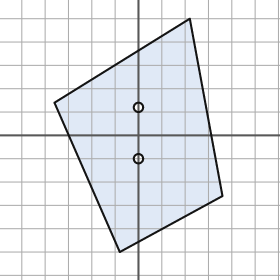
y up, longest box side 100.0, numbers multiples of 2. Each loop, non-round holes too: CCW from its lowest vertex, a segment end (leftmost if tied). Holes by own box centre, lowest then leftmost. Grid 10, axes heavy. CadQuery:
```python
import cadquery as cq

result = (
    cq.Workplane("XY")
    .moveTo(-8.0, -50.0)
    .lineTo(36.0, -26.0)
    .lineTo(22.0, 50.0)
    .lineTo(-36.0, 14.0)
    .close()
    .moveTo(0.0, -10.0)
    .circle(2.0)
    .moveTo(0.0, 12.0)
    .circle(2.0)
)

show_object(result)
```